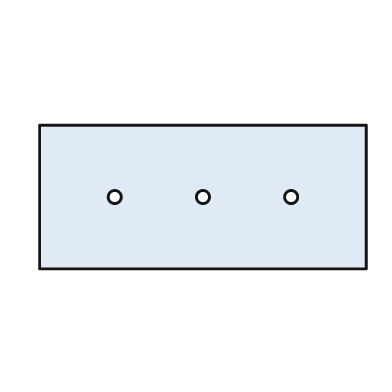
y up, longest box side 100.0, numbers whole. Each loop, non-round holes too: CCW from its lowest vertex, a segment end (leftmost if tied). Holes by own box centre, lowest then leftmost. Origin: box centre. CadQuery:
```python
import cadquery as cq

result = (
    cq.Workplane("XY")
    .moveTo(-50.0, -22.0)
    .lineTo(50.0, -22.0)
    .lineTo(50.0, 22.0)
    .lineTo(-50.0, 22.0)
    .close()
    .moveTo(-27.0, 0.0)
    .circle(2.0)
    .moveTo(0.0, 0.0)
    .circle(2.0)
    .moveTo(27.0, 0.0)
    .circle(2.0)
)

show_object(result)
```